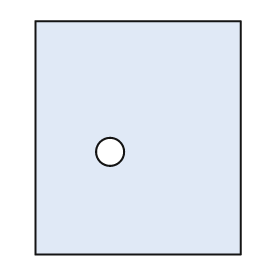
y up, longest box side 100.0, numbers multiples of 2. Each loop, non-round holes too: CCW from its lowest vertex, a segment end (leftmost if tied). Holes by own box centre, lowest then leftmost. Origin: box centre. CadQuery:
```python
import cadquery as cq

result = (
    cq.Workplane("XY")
    .moveTo(-44.0, -50.0)
    .lineTo(44.0, -50.0)
    .lineTo(44.0, 50.0)
    .lineTo(-44.0, 50.0)
    .close()
    .moveTo(-12.0, -6.0)
    .circle(6.0)
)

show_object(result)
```